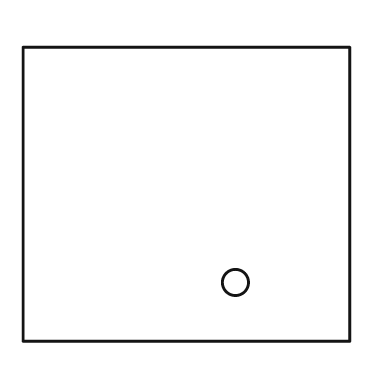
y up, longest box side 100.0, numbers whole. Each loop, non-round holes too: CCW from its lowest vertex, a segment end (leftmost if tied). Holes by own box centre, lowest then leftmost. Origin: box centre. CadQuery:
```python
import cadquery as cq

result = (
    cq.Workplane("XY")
    .moveTo(-50.0, -45.0)
    .lineTo(50.0, -45.0)
    .lineTo(50.0, 45.0)
    .lineTo(-50.0, 45.0)
    .close()
    .moveTo(15.0, -27.0)
    .circle(4.0)
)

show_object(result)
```